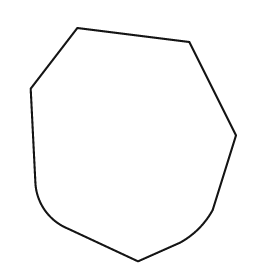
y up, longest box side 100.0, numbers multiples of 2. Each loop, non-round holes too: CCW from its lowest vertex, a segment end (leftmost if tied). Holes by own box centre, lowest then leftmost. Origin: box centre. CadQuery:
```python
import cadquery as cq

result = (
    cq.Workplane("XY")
    .moveTo(2.0, -50.0)
    .lineTo(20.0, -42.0)
    .threePointArc((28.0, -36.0), (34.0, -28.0))
    .lineTo(44.0, 4.0)
    .lineTo(24.0, 44.0)
    .lineTo(-24.0, 50.0)
    .lineTo(-44.0, 24.0)
    .lineTo(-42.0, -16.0)
    .threePointArc((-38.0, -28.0), (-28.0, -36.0))
    .close()
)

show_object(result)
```